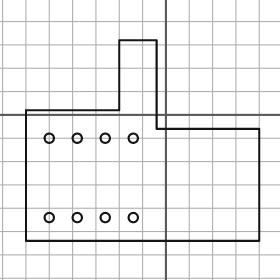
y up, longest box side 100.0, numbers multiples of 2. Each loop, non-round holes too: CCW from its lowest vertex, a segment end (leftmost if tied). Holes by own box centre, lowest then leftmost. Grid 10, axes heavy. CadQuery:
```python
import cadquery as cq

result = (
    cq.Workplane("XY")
    .moveTo(-60.0, -54.0)
    .lineTo(40.0, -54.0)
    .lineTo(40.0, -6.0)
    .lineTo(-4.0, -6.0)
    .lineTo(-4.0, 32.0)
    .lineTo(-20.0, 32.0)
    .lineTo(-20.0, 2.0)
    .lineTo(-60.0, 2.0)
    .close()
    .moveTo(-50.0, -44.0)
    .circle(2.0)
    .moveTo(-38.0, -44.0)
    .circle(2.0)
    .moveTo(-26.0, -44.0)
    .circle(2.0)
    .moveTo(-14.0, -44.0)
    .circle(2.0)
    .moveTo(-50.0, -10.0)
    .circle(2.0)
    .moveTo(-38.0, -10.0)
    .circle(2.0)
    .moveTo(-26.0, -10.0)
    .circle(2.0)
    .moveTo(-14.0, -10.0)
    .circle(2.0)
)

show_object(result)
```